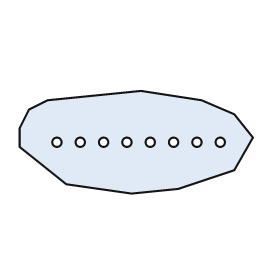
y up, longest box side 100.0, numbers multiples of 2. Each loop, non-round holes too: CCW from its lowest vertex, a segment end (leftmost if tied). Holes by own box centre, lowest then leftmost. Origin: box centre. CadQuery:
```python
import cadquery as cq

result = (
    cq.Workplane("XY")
    .moveTo(-2.0, -22.0)
    .lineTo(18.0, -20.0)
    .lineTo(42.0, -12.0)
    .lineTo(50.0, 2.0)
    .lineTo(42.0, 12.0)
    .lineTo(28.0, 18.0)
    .lineTo(2.0, 22.0)
    .lineTo(-38.0, 18.0)
    .lineTo(-46.0, 14.0)
    .lineTo(-50.0, 6.0)
    .lineTo(-50.0, -2.0)
    .lineTo(-30.0, -18.0)
    .close()
    .moveTo(-34.0, 0.0)
    .circle(2.0)
    .moveTo(-24.0, 0.0)
    .circle(2.0)
    .moveTo(-14.0, 0.0)
    .circle(2.0)
    .moveTo(-4.0, 0.0)
    .circle(2.0)
    .moveTo(6.0, 0.0)
    .circle(2.0)
    .moveTo(16.0, 0.0)
    .circle(2.0)
    .moveTo(26.0, 0.0)
    .circle(2.0)
    .moveTo(36.0, 0.0)
    .circle(2.0)
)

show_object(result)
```